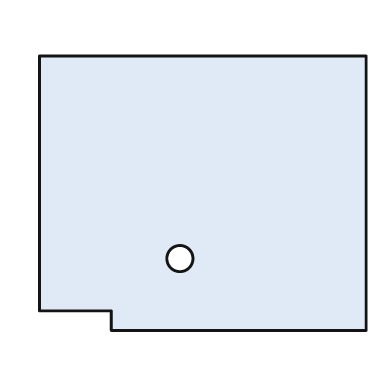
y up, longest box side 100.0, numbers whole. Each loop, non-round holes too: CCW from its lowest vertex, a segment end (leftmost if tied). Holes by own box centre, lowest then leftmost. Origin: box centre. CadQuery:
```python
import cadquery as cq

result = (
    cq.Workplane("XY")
    .moveTo(-28.0, -42.0)
    .lineTo(50.0, -42.0)
    .lineTo(50.0, 42.0)
    .lineTo(-50.0, 42.0)
    .lineTo(-50.0, -36.0)
    .lineTo(-28.0, -36.0)
    .close()
    .moveTo(-7.0, -20.0)
    .circle(4.0)
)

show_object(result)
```